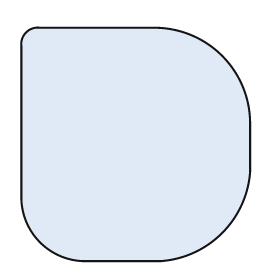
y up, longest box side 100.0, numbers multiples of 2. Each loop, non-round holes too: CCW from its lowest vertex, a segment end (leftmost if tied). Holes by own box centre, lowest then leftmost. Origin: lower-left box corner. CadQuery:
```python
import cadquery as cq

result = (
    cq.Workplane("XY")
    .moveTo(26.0, 0.0)
    .lineTo(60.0, 0.0)
    .threePointArc((86.0, 12.0), (98.0, 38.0))
    .lineTo(98.0, 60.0)
    .threePointArc((86.0, 88.0), (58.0, 100.0))
    .lineTo(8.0, 100.0)
    .threePointArc((2.0, 98.0), (0.0, 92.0))
    .lineTo(0.0, 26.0)
    .threePointArc((8.0, 8.0), (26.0, 0.0))
    .close()
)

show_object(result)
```